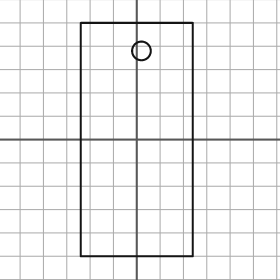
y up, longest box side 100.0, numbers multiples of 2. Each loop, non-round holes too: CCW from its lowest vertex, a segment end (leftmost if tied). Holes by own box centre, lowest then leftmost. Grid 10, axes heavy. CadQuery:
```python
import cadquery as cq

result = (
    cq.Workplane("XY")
    .moveTo(-24.0, -50.0)
    .lineTo(24.0, -50.0)
    .lineTo(24.0, 50.0)
    .lineTo(-24.0, 50.0)
    .close()
    .moveTo(2.0, 38.0)
    .circle(4.0)
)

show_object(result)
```